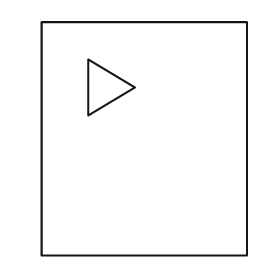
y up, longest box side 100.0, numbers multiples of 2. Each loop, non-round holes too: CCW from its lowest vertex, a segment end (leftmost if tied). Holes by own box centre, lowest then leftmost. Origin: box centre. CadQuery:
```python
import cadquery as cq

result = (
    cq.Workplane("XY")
    .moveTo(-44.0, -50.0)
    .lineTo(44.0, -50.0)
    .lineTo(44.0, 50.0)
    .lineTo(-44.0, 50.0)
    .close()
    .moveTo(-24.0, 10.0)
    .lineTo(-4.0, 22.0)
    .lineTo(-24.0, 34.0)
    .close()
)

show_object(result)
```